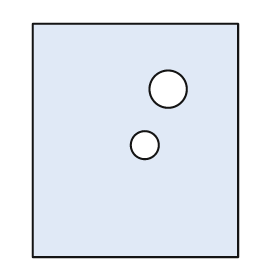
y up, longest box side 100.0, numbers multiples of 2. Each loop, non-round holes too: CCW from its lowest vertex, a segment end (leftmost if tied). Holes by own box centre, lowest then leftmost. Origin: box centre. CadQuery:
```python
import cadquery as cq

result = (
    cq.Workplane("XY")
    .moveTo(-44.0, -50.0)
    .lineTo(44.0, -50.0)
    .lineTo(44.0, 50.0)
    .lineTo(-44.0, 50.0)
    .close()
    .moveTo(4.0, -2.0)
    .circle(6.0)
    .moveTo(14.0, 22.0)
    .circle(8.0)
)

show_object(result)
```